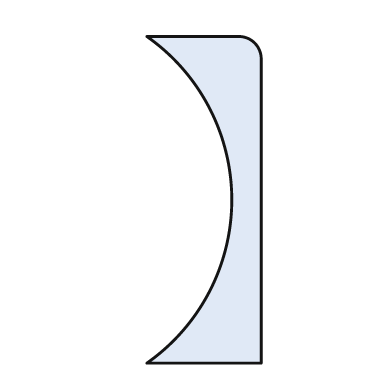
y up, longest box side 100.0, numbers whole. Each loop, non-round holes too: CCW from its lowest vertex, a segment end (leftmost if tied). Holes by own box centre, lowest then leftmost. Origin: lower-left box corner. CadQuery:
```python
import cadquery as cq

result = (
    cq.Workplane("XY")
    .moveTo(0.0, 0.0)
    .lineTo(35.0, 0.0)
    .lineTo(35.0, 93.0)
    .threePointArc((33.0, 98.0), (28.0, 100.0))
    .lineTo(0.0, 100.0)
    .threePointArc((26.0, 50.0), (0.0, 0.0))
    .close()
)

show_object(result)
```